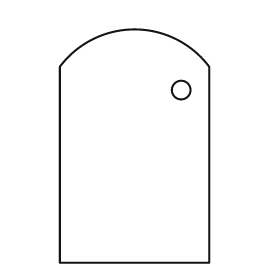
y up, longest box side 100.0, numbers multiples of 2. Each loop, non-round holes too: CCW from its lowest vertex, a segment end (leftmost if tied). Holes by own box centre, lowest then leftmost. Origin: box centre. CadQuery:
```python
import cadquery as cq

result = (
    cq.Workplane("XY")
    .moveTo(-32.0, -50.0)
    .lineTo(32.0, -50.0)
    .lineTo(32.0, 34.0)
    .threePointArc((0.0, 50.0), (-32.0, 34.0))
    .close()
    .moveTo(20.0, 24.0)
    .circle(4.0)
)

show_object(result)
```